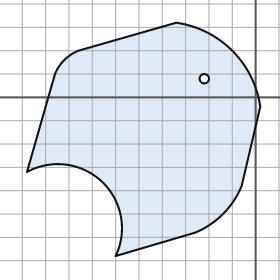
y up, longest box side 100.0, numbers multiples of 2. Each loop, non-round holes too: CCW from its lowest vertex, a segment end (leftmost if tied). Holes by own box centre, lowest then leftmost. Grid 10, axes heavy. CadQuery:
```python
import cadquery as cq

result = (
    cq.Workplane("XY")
    .moveTo(-60.0, -68.0)
    .lineTo(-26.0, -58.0)
    .threePointArc((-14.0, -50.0), (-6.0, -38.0))
    .lineTo(2.0, -4.0)
    .threePointArc((-10.0, 20.0), (-34.0, 32.0))
    .lineTo(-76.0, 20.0)
    .threePointArc((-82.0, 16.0), (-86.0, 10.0))
    .lineTo(-98.0, -32.0)
    .threePointArc((-66.0, -36.0), (-60.0, -68.0))
    .close()
    .moveTo(-22.0, 8.0)
    .circle(2.0)
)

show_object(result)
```